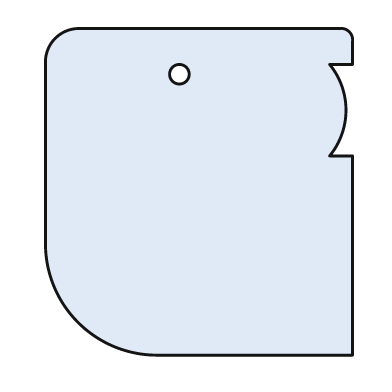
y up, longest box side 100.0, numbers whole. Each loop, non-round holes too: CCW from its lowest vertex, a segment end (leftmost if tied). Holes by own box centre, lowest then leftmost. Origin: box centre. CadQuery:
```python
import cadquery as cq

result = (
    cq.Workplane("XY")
    .moveTo(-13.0, -50.0)
    .lineTo(47.0, -50.0)
    .lineTo(47.0, 11.0)
    .lineTo(40.0, 11.0)
    .threePointArc((45.0, 25.0), (40.0, 39.0))
    .lineTo(47.0, 39.0)
    .lineTo(47.0, 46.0)
    .threePointArc((46.0, 49.0), (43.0, 50.0))
    .lineTo(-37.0, 50.0)
    .threePointArc((-44.0, 47.0), (-47.0, 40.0))
    .lineTo(-47.0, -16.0)
    .threePointArc((-37.0, -40.0), (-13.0, -50.0))
    .close()
    .moveTo(-6.0, 36.0)
    .circle(3.0)
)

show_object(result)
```